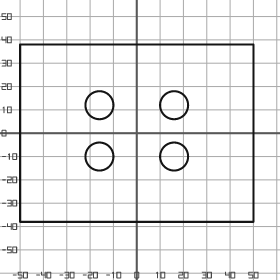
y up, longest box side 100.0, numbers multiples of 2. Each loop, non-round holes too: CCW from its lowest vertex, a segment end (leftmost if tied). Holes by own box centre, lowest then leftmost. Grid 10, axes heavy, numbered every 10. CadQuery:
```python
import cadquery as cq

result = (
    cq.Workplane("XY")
    .moveTo(-50.0, -38.0)
    .lineTo(50.0, -38.0)
    .lineTo(50.0, 38.0)
    .lineTo(-50.0, 38.0)
    .close()
    .moveTo(-16.0, -10.0)
    .circle(6.0)
    .moveTo(16.0, -10.0)
    .circle(6.0)
    .moveTo(-16.0, 12.0)
    .circle(6.0)
    .moveTo(16.0, 12.0)
    .circle(6.0)
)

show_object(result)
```